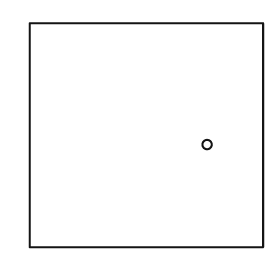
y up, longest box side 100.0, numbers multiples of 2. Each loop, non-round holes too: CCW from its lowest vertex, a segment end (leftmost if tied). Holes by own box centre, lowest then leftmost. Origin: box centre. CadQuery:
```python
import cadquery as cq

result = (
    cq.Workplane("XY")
    .moveTo(-50.0, -48.0)
    .lineTo(50.0, -48.0)
    .lineTo(50.0, 48.0)
    .lineTo(-50.0, 48.0)
    .close()
    .moveTo(26.0, -4.0)
    .circle(2.0)
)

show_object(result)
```